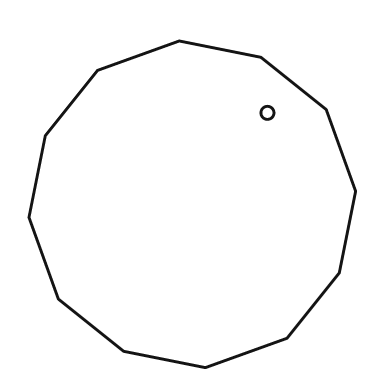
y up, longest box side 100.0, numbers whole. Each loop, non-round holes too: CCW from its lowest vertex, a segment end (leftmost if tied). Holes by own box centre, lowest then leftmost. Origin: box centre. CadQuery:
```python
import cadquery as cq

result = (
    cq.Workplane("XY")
    .moveTo(4.0, -50.0)
    .lineTo(29.0, -41.0)
    .lineTo(45.0, -21.0)
    .lineTo(50.0, 4.0)
    .lineTo(41.0, 29.0)
    .lineTo(21.0, 45.0)
    .lineTo(-4.0, 50.0)
    .lineTo(-29.0, 41.0)
    .lineTo(-45.0, 21.0)
    .lineTo(-50.0, -4.0)
    .lineTo(-41.0, -29.0)
    .lineTo(-21.0, -45.0)
    .close()
    .moveTo(23.0, 28.0)
    .circle(2.0)
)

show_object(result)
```